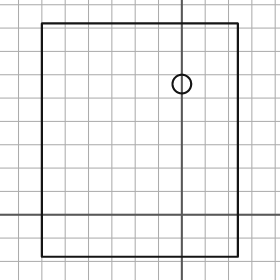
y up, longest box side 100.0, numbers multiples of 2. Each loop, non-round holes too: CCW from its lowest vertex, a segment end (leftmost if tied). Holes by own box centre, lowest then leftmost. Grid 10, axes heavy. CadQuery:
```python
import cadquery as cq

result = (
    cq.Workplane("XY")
    .moveTo(-60.0, -18.0)
    .lineTo(24.0, -18.0)
    .lineTo(24.0, 82.0)
    .lineTo(-60.0, 82.0)
    .close()
    .moveTo(0.0, 56.0)
    .circle(4.0)
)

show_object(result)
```